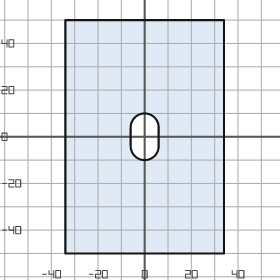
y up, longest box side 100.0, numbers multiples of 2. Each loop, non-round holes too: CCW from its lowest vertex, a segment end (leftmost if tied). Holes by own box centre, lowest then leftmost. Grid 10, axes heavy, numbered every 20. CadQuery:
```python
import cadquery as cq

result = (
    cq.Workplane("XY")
    .moveTo(-34.0, -50.0)
    .lineTo(34.0, -50.0)
    .lineTo(34.0, 50.0)
    .lineTo(-34.0, 50.0)
    .close()
    .moveTo(-6.0, -4.0)
    .threePointArc((0.0, -10.0), (6.0, -4.0))
    .lineTo(6.0, 4.0)
    .threePointArc((0.0, 10.0), (-6.0, 4.0))
    .close()
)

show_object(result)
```